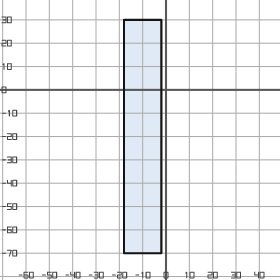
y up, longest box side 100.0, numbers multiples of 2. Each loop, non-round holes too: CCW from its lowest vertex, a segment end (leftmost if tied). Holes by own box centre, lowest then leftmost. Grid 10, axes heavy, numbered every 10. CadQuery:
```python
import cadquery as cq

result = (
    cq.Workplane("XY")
    .moveTo(-18.0, -70.0)
    .lineTo(-2.0, -70.0)
    .lineTo(-2.0, 30.0)
    .lineTo(-18.0, 30.0)
    .close()
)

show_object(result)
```